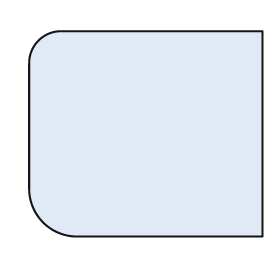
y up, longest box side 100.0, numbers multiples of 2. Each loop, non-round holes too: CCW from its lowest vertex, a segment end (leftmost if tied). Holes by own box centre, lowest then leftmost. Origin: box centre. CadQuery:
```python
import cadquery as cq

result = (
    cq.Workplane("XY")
    .moveTo(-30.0, -44.0)
    .lineTo(50.0, -44.0)
    .lineTo(50.0, 44.0)
    .lineTo(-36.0, 44.0)
    .threePointArc((-46.0, 40.0), (-50.0, 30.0))
    .lineTo(-50.0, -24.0)
    .threePointArc((-44.0, -38.0), (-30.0, -44.0))
    .close()
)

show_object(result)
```